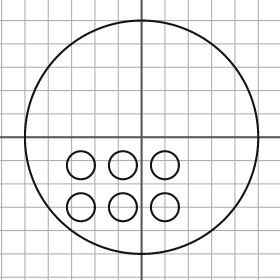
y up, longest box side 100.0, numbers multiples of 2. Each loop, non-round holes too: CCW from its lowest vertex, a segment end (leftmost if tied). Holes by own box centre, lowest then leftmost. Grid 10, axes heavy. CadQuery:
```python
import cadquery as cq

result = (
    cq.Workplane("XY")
    .moveTo(0.0, 0.0)
    .circle(50.0)
    .moveTo(-26.0, -30.0)
    .circle(6.0)
    .moveTo(-8.0, -30.0)
    .circle(6.0)
    .moveTo(10.0, -30.0)
    .circle(6.0)
    .moveTo(-26.0, -12.0)
    .circle(6.0)
    .moveTo(-8.0, -12.0)
    .circle(6.0)
    .moveTo(10.0, -12.0)
    .circle(6.0)
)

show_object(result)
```